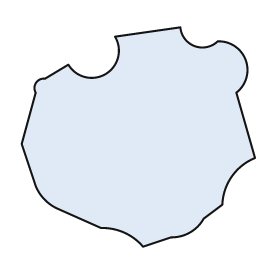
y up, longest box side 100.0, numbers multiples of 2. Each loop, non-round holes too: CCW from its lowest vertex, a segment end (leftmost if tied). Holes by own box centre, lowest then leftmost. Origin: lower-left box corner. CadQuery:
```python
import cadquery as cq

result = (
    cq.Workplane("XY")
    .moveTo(52.0, 0.0)
    .lineTo(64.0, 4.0)
    .threePointArc((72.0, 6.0), (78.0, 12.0))
    .lineTo(86.0, 18.0)
    .threePointArc((90.0, 30.0), (100.0, 38.0))
    .lineTo(92.0, 66.0)
    .threePointArc((96.0, 80.0), (84.0, 88.0))
    .threePointArc((74.0, 86.0), (68.0, 94.0))
    .lineTo(40.0, 90.0)
    .threePointArc((36.0, 74.0), (20.0, 78.0))
    .lineTo(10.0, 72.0)
    .threePointArc((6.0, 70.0), (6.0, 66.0))
    .lineTo(0.0, 44.0)
    .lineTo(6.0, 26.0)
    .threePointArc((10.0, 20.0), (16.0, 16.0))
    .lineTo(34.0, 8.0)
    .threePointArc((44.0, 6.0), (52.0, 0.0))
    .close()
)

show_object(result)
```